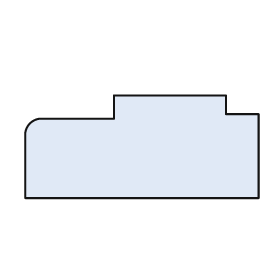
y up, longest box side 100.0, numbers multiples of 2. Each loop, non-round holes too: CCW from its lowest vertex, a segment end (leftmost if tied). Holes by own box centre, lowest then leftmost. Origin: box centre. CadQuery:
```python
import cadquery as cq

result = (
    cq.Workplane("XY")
    .moveTo(-50.0, -22.0)
    .lineTo(50.0, -22.0)
    .lineTo(50.0, 14.0)
    .lineTo(36.0, 14.0)
    .lineTo(36.0, 22.0)
    .lineTo(-12.0, 22.0)
    .lineTo(-12.0, 12.0)
    .lineTo(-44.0, 12.0)
    .threePointArc((-48.0, 10.0), (-50.0, 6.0))
    .close()
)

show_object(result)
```